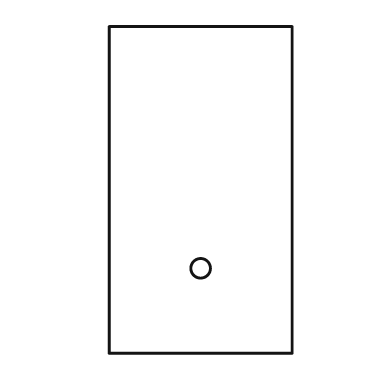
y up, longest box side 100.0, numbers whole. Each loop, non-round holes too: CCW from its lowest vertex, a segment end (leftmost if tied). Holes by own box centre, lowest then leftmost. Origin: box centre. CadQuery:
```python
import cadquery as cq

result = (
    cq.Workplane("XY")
    .moveTo(-28.0, -50.0)
    .lineTo(28.0, -50.0)
    .lineTo(28.0, 50.0)
    .lineTo(-28.0, 50.0)
    .close()
    .moveTo(0.0, -24.0)
    .circle(3.0)
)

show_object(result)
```